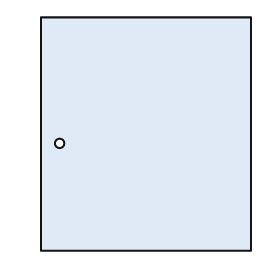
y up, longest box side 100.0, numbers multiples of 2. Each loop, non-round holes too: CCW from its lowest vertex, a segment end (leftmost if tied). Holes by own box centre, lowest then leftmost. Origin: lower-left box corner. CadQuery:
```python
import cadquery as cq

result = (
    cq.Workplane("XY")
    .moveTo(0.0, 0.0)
    .lineTo(90.0, 0.0)
    .lineTo(90.0, 100.0)
    .lineTo(0.0, 100.0)
    .close()
    .moveTo(8.0, 46.0)
    .circle(2.0)
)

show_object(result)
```